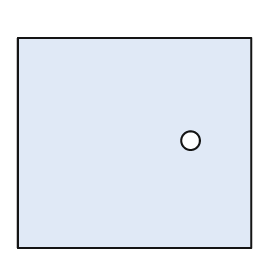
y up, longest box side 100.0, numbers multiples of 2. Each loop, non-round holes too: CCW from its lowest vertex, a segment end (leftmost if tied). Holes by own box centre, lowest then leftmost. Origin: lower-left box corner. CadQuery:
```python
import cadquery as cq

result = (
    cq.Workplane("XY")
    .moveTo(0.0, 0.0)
    .lineTo(100.0, 0.0)
    .lineTo(100.0, 90.0)
    .lineTo(0.0, 90.0)
    .close()
    .moveTo(74.0, 46.0)
    .circle(4.0)
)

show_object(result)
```